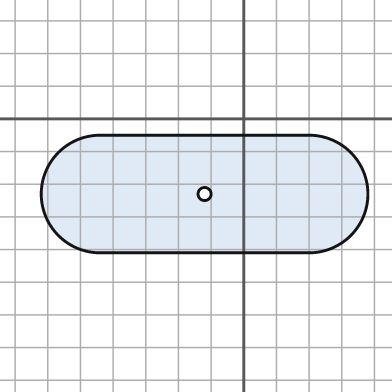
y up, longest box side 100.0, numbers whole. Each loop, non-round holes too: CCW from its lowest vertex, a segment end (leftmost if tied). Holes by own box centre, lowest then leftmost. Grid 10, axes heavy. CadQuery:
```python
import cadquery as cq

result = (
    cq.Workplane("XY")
    .moveTo(-44.0, -41.0)
    .lineTo(20.0, -41.0)
    .threePointArc((38.0, -23.0), (20.0, -5.0))
    .lineTo(-44.0, -5.0)
    .threePointArc((-62.0, -23.0), (-44.0, -41.0))
    .close()
    .moveTo(-12.0, -23.0)
    .circle(2.0)
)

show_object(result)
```